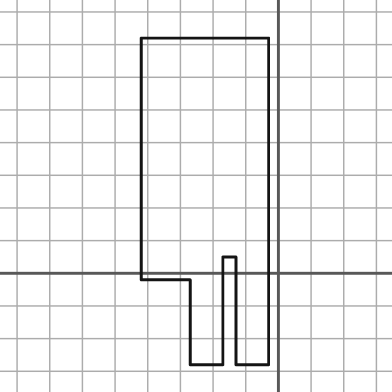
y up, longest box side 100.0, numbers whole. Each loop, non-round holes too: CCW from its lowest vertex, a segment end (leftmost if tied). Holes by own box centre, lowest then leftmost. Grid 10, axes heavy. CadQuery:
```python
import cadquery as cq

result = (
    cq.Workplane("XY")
    .moveTo(-27.0, -28.0)
    .lineTo(-17.0, -28.0)
    .lineTo(-17.0, 5.0)
    .lineTo(-13.0, 5.0)
    .lineTo(-13.0, -28.0)
    .lineTo(-3.0, -28.0)
    .lineTo(-3.0, 72.0)
    .lineTo(-42.0, 72.0)
    .lineTo(-42.0, -2.0)
    .lineTo(-27.0, -2.0)
    .close()
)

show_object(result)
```